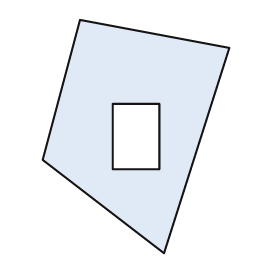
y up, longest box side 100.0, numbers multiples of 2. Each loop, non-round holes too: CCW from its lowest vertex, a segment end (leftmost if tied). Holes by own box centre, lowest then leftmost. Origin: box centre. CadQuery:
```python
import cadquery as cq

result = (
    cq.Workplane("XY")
    .moveTo(12.0, -50.0)
    .lineTo(40.0, 38.0)
    .lineTo(-24.0, 50.0)
    .lineTo(-40.0, -10.0)
    .close()
    .moveTo(-10.0, -14.0)
    .lineTo(10.0, -14.0)
    .lineTo(10.0, 14.0)
    .lineTo(-10.0, 14.0)
    .close()
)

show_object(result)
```